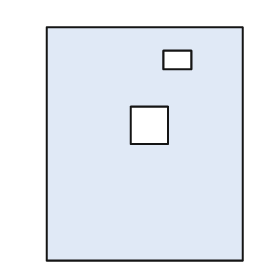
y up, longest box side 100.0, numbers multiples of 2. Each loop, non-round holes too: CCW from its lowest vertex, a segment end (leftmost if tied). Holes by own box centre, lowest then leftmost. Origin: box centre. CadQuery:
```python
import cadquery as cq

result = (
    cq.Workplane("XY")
    .moveTo(-42.0, -50.0)
    .lineTo(42.0, -50.0)
    .lineTo(42.0, 50.0)
    .lineTo(-42.0, 50.0)
    .close()
    .moveTo(-6.0, 0.0)
    .lineTo(10.0, 0.0)
    .lineTo(10.0, 16.0)
    .lineTo(-6.0, 16.0)
    .close()
    .moveTo(8.0, 32.0)
    .lineTo(20.0, 32.0)
    .lineTo(20.0, 40.0)
    .lineTo(8.0, 40.0)
    .close()
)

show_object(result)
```